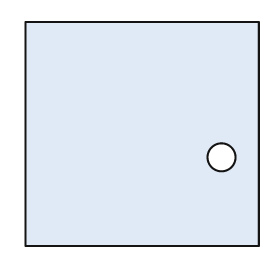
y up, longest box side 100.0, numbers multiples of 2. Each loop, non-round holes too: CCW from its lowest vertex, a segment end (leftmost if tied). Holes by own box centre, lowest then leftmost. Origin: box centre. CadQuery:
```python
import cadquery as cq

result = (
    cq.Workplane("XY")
    .moveTo(-50.0, -48.0)
    .lineTo(50.0, -48.0)
    .lineTo(50.0, 48.0)
    .lineTo(-50.0, 48.0)
    .close()
    .moveTo(34.0, -10.0)
    .circle(6.0)
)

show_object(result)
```